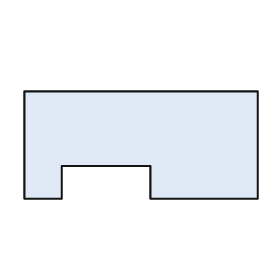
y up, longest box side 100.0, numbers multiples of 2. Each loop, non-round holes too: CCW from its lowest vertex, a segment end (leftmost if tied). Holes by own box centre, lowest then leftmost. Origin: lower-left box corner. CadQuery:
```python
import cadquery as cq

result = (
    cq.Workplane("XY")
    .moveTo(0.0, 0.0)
    .lineTo(16.0, 0.0)
    .lineTo(16.0, 14.0)
    .lineTo(54.0, 14.0)
    .lineTo(54.0, 0.0)
    .lineTo(100.0, 0.0)
    .lineTo(100.0, 46.0)
    .lineTo(0.0, 46.0)
    .close()
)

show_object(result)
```